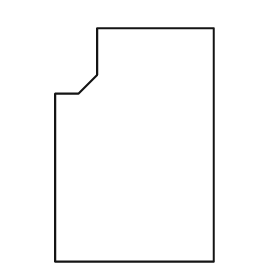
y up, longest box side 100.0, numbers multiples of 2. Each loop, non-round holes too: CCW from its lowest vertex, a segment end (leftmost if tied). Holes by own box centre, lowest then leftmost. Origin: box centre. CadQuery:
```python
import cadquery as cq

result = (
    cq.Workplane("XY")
    .moveTo(-34.0, -50.0)
    .lineTo(34.0, -50.0)
    .lineTo(34.0, 50.0)
    .lineTo(-16.0, 50.0)
    .lineTo(-16.0, 30.0)
    .lineTo(-24.0, 22.0)
    .lineTo(-34.0, 22.0)
    .close()
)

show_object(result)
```